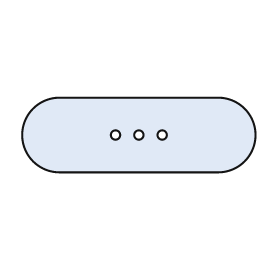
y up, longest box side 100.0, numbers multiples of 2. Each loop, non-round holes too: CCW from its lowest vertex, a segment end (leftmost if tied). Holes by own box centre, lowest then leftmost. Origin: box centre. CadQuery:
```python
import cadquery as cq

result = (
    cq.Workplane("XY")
    .moveTo(-34.0, -16.0)
    .lineTo(34.0, -16.0)
    .threePointArc((50.0, 0.0), (34.0, 16.0))
    .lineTo(-34.0, 16.0)
    .threePointArc((-50.0, 0.0), (-34.0, -16.0))
    .close()
    .moveTo(-10.0, 0.0)
    .circle(2.0)
    .moveTo(0.0, 0.0)
    .circle(2.0)
    .moveTo(10.0, 0.0)
    .circle(2.0)
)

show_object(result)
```